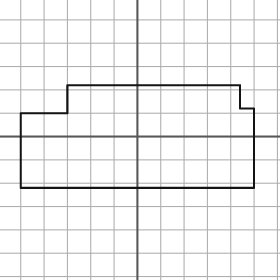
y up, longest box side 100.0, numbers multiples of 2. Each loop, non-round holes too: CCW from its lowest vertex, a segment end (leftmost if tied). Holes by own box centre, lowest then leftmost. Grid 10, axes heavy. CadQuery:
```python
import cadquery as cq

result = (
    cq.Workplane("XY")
    .moveTo(-50.0, -22.0)
    .lineTo(50.0, -22.0)
    .lineTo(50.0, 12.0)
    .lineTo(44.0, 12.0)
    .lineTo(44.0, 22.0)
    .lineTo(-30.0, 22.0)
    .lineTo(-30.0, 10.0)
    .lineTo(-50.0, 10.0)
    .close()
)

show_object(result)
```